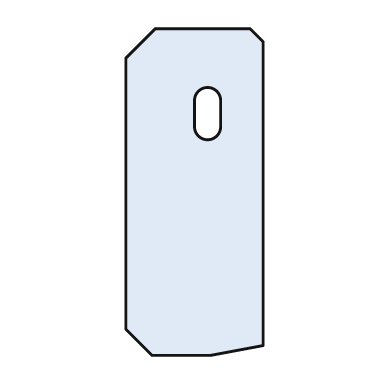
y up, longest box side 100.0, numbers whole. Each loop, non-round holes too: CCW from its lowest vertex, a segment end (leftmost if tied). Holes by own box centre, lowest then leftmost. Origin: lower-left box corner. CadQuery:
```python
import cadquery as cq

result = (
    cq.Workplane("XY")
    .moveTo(8.0, 0.0)
    .lineTo(26.0, 0.0)
    .lineTo(42.0, 3.0)
    .lineTo(42.0, 96.0)
    .lineTo(38.0, 100.0)
    .lineTo(9.0, 100.0)
    .lineTo(0.0, 91.0)
    .lineTo(0.0, 8.0)
    .close()
    .moveTo(21.0, 70.0)
    .threePointArc((25.0, 66.0), (29.0, 70.0))
    .lineTo(29.0, 78.0)
    .threePointArc((25.0, 82.0), (21.0, 78.0))
    .close()
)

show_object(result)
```